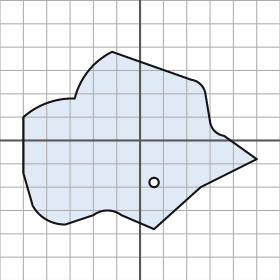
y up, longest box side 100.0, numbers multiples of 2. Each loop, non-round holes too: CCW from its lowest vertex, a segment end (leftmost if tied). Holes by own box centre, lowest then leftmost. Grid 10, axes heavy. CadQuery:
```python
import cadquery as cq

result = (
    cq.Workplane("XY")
    .moveTo(6.0, -38.0)
    .lineTo(26.0, -20.0)
    .lineTo(50.0, -8.0)
    .lineTo(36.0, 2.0)
    .threePointArc((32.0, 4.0), (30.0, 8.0))
    .lineTo(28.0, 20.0)
    .threePointArc((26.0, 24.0), (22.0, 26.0))
    .lineTo(-12.0, 38.0)
    .threePointArc((-22.0, 30.0), (-28.0, 18.0))
    .threePointArc((-40.0, 16.0), (-50.0, 10.0))
    .lineTo(-50.0, -14.0)
    .lineTo(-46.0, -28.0)
    .threePointArc((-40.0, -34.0), (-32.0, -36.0))
    .lineTo(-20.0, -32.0)
    .threePointArc((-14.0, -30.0), (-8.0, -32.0))
    .close()
    .moveTo(6.0, -18.0)
    .circle(2.0)
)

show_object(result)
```